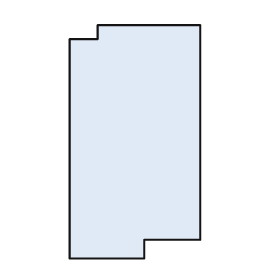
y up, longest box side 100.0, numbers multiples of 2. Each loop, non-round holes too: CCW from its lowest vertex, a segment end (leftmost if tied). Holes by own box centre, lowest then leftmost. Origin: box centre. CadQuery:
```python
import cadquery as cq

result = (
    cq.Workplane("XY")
    .moveTo(-28.0, -50.0)
    .lineTo(4.0, -50.0)
    .lineTo(4.0, -42.0)
    .lineTo(28.0, -42.0)
    .lineTo(28.0, 50.0)
    .lineTo(-16.0, 50.0)
    .lineTo(-16.0, 44.0)
    .lineTo(-28.0, 44.0)
    .close()
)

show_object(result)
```